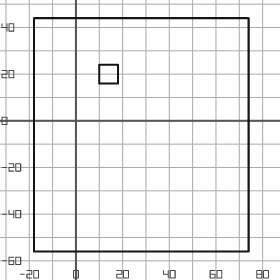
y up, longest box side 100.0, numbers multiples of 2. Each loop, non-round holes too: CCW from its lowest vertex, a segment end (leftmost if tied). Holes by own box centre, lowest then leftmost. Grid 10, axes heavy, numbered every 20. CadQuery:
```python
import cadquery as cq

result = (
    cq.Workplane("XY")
    .moveTo(-18.0, -56.0)
    .lineTo(74.0, -56.0)
    .lineTo(74.0, 44.0)
    .lineTo(-18.0, 44.0)
    .close()
    .moveTo(10.0, 16.0)
    .lineTo(18.0, 16.0)
    .lineTo(18.0, 24.0)
    .lineTo(10.0, 24.0)
    .close()
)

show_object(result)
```